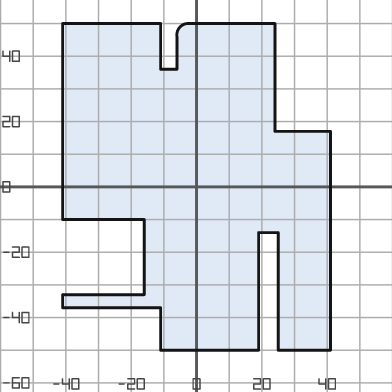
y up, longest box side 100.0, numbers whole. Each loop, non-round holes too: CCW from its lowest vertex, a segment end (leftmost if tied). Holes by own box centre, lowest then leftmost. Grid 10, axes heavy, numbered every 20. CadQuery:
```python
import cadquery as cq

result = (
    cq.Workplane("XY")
    .moveTo(-11.0, -50.0)
    .lineTo(19.0, -50.0)
    .lineTo(19.0, -14.0)
    .lineTo(25.0, -14.0)
    .lineTo(25.0, -50.0)
    .lineTo(41.0, -50.0)
    .lineTo(41.0, 17.0)
    .lineTo(24.0, 17.0)
    .lineTo(24.0, 50.0)
    .lineTo(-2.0, 50.0)
    .threePointArc((-5.0, 49.0), (-6.0, 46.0))
    .lineTo(-6.0, 36.0)
    .lineTo(-11.0, 36.0)
    .lineTo(-11.0, 50.0)
    .lineTo(-41.0, 50.0)
    .lineTo(-41.0, -10.0)
    .lineTo(-16.0, -10.0)
    .lineTo(-16.0, -33.0)
    .lineTo(-41.0, -33.0)
    .lineTo(-41.0, -37.0)
    .lineTo(-11.0, -37.0)
    .close()
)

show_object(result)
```